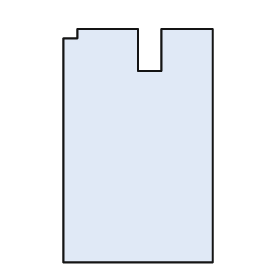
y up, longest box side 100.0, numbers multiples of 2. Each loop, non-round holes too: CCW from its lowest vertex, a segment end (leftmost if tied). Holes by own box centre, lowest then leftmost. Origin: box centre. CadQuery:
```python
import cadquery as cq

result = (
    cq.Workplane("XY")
    .moveTo(-32.0, -50.0)
    .lineTo(32.0, -50.0)
    .lineTo(32.0, 50.0)
    .lineTo(10.0, 50.0)
    .lineTo(10.0, 32.0)
    .lineTo(0.0, 32.0)
    .lineTo(0.0, 50.0)
    .lineTo(-26.0, 50.0)
    .lineTo(-26.0, 46.0)
    .lineTo(-32.0, 46.0)
    .close()
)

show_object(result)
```